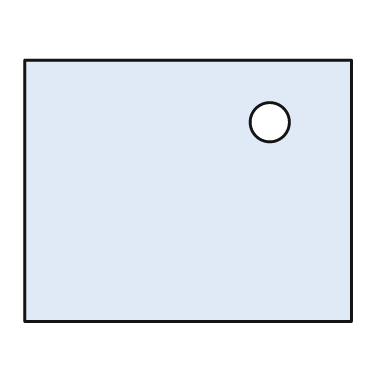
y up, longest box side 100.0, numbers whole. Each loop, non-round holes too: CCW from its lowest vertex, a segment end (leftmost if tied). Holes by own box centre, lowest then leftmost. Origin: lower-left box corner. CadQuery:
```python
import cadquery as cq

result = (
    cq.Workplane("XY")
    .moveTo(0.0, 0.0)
    .lineTo(100.0, 0.0)
    .lineTo(100.0, 80.0)
    .lineTo(0.0, 80.0)
    .close()
    .moveTo(75.0, 61.0)
    .circle(6.0)
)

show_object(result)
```